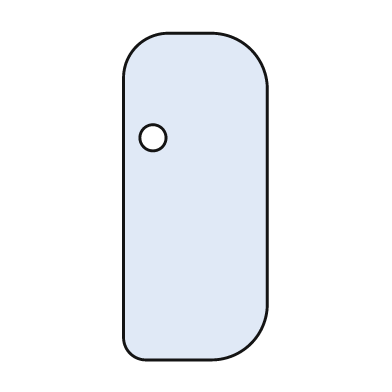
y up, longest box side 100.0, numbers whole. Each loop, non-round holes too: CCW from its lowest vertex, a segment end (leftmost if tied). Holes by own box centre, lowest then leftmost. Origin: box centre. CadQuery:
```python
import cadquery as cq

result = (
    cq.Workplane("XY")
    .moveTo(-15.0, -50.0)
    .lineTo(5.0, -50.0)
    .threePointArc((17.0, -45.0), (22.0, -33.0))
    .lineTo(22.0, 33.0)
    .threePointArc((17.0, 45.0), (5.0, 50.0))
    .lineTo(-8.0, 50.0)
    .threePointArc((-18.0, 46.0), (-22.0, 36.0))
    .lineTo(-22.0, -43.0)
    .threePointArc((-20.0, -48.0), (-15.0, -50.0))
    .close()
    .moveTo(-13.0, 18.0)
    .circle(4.0)
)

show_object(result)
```